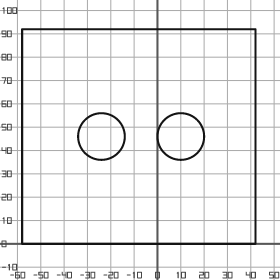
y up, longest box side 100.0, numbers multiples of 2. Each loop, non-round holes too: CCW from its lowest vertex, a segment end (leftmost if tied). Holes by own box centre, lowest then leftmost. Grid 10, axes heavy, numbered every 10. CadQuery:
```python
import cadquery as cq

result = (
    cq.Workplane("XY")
    .moveTo(-58.0, 0.0)
    .lineTo(42.0, 0.0)
    .lineTo(42.0, 92.0)
    .lineTo(-58.0, 92.0)
    .close()
    .moveTo(-24.0, 46.0)
    .circle(10.0)
    .moveTo(10.0, 46.0)
    .circle(10.0)
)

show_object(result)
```